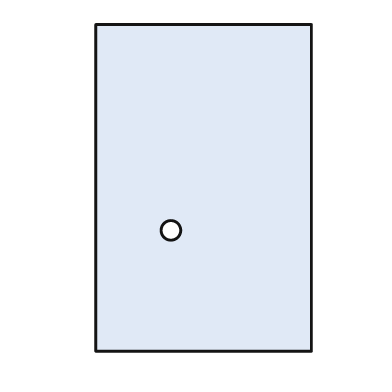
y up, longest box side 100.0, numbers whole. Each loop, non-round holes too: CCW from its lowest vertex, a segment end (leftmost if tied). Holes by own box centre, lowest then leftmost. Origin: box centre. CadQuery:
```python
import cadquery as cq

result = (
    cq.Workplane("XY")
    .moveTo(-33.0, -50.0)
    .lineTo(33.0, -50.0)
    .lineTo(33.0, 50.0)
    .lineTo(-33.0, 50.0)
    .close()
    .moveTo(-10.0, -13.0)
    .circle(3.0)
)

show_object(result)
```